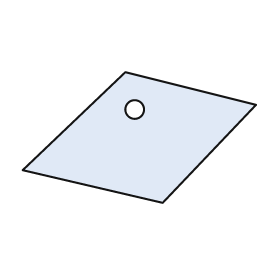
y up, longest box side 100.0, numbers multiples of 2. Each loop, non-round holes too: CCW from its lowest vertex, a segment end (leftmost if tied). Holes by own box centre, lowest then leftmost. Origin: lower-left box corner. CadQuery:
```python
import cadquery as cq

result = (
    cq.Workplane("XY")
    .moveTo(60.0, 0.0)
    .lineTo(100.0, 42.0)
    .lineTo(44.0, 56.0)
    .lineTo(0.0, 14.0)
    .close()
    .moveTo(48.0, 40.0)
    .circle(4.0)
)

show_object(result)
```